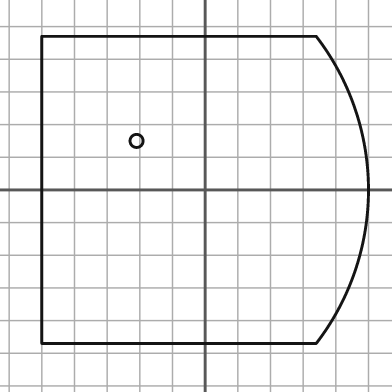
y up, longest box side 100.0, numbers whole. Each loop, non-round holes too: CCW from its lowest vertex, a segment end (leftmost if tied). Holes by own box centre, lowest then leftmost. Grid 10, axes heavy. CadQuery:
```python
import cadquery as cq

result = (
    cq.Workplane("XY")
    .moveTo(-50.0, -47.0)
    .lineTo(34.0, -47.0)
    .threePointArc((50.0, 0.0), (34.0, 47.0))
    .lineTo(-50.0, 47.0)
    .close()
    .moveTo(-21.0, 15.0)
    .circle(2.0)
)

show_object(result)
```